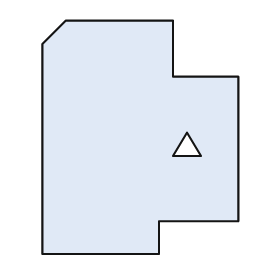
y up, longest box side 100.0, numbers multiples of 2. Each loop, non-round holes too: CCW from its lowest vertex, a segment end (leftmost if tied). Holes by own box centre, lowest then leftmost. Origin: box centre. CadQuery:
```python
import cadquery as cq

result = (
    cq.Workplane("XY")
    .moveTo(-42.0, -50.0)
    .lineTo(8.0, -50.0)
    .lineTo(8.0, -36.0)
    .lineTo(42.0, -36.0)
    .lineTo(42.0, 26.0)
    .lineTo(14.0, 26.0)
    .lineTo(14.0, 50.0)
    .lineTo(-32.0, 50.0)
    .lineTo(-42.0, 40.0)
    .close()
    .moveTo(14.0, -8.0)
    .lineTo(26.0, -8.0)
    .lineTo(20.0, 2.0)
    .close()
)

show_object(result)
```